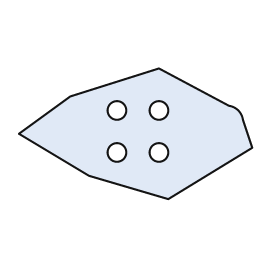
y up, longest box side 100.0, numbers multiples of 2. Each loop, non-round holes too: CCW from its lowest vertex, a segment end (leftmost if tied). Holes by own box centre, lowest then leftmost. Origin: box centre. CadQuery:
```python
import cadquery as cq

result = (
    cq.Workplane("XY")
    .moveTo(14.0, -28.0)
    .lineTo(50.0, -6.0)
    .lineTo(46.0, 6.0)
    .threePointArc((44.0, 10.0), (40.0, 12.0))
    .lineTo(10.0, 28.0)
    .lineTo(-28.0, 16.0)
    .lineTo(-50.0, 0.0)
    .lineTo(-20.0, -18.0)
    .close()
    .moveTo(-8.0, -8.0)
    .circle(4.0)
    .moveTo(10.0, -8.0)
    .circle(4.0)
    .moveTo(-8.0, 10.0)
    .circle(4.0)
    .moveTo(10.0, 10.0)
    .circle(4.0)
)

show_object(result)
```